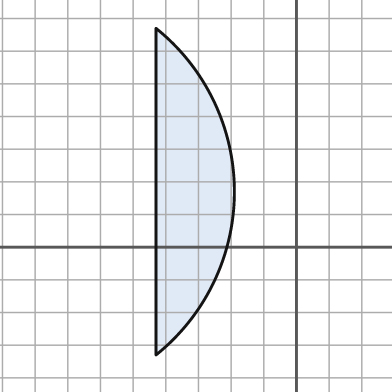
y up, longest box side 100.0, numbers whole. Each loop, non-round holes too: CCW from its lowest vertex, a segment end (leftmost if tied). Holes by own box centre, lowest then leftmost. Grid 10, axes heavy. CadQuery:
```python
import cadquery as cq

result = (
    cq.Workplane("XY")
    .moveTo(-43.0, -33.0)
    .threePointArc((-19.0, 17.0), (-43.0, 67.0))
    .close()
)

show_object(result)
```